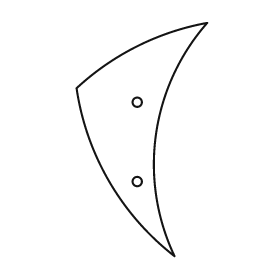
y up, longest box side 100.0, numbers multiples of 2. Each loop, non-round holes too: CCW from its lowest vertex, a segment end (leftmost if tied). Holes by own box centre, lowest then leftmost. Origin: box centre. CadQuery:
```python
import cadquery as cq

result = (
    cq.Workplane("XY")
    .moveTo(14.0, -50.0)
    .threePointArc((6.0, 2.0), (28.0, 50.0))
    .threePointArc((-2.0, 40.0), (-28.0, 22.0))
    .threePointArc((-14.0, -18.0), (14.0, -50.0))
    .close()
    .moveTo(-2.0, -18.0)
    .circle(2.0)
    .moveTo(-2.0, 16.0)
    .circle(2.0)
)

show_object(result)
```